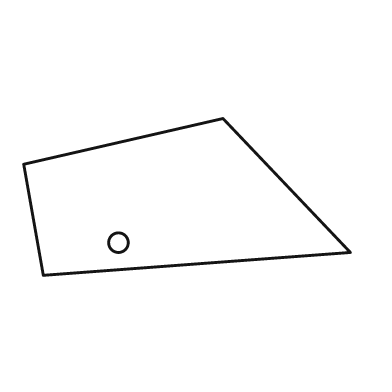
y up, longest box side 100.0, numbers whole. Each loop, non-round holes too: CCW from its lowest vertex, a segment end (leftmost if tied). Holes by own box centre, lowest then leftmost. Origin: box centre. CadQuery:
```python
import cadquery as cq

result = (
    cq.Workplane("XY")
    .moveTo(-44.0, -24.0)
    .lineTo(50.0, -17.0)
    .lineTo(11.0, 24.0)
    .lineTo(-50.0, 10.0)
    .close()
    .moveTo(-21.0, -14.0)
    .circle(3.0)
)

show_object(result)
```